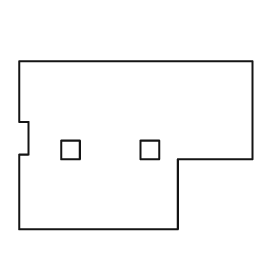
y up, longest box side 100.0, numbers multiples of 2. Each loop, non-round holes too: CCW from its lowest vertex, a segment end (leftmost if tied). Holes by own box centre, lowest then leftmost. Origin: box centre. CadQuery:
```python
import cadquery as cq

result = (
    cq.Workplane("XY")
    .moveTo(-50.0, -36.0)
    .lineTo(18.0, -36.0)
    .lineTo(18.0, -6.0)
    .lineTo(50.0, -6.0)
    .lineTo(50.0, 36.0)
    .lineTo(-50.0, 36.0)
    .lineTo(-50.0, 10.0)
    .lineTo(-46.0, 10.0)
    .lineTo(-46.0, -4.0)
    .lineTo(-50.0, -4.0)
    .close()
    .moveTo(-32.0, -6.0)
    .lineTo(-24.0, -6.0)
    .lineTo(-24.0, 2.0)
    .lineTo(-32.0, 2.0)
    .close()
    .moveTo(2.0, -6.0)
    .lineTo(10.0, -6.0)
    .lineTo(10.0, 2.0)
    .lineTo(2.0, 2.0)
    .close()
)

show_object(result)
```